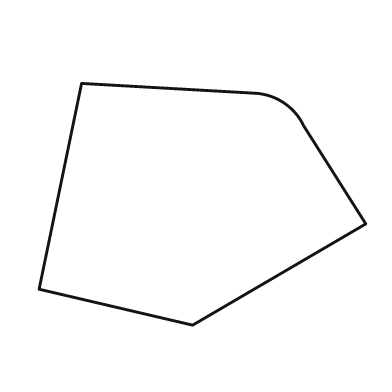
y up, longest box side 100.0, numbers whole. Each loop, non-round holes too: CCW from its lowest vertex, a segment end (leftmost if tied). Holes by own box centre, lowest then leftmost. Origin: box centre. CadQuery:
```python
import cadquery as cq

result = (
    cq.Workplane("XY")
    .moveTo(-3.0, -37.0)
    .lineTo(50.0, -6.0)
    .lineTo(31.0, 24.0)
    .threePointArc((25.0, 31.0), (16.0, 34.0))
    .lineTo(-37.0, 37.0)
    .lineTo(-50.0, -26.0)
    .close()
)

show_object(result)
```